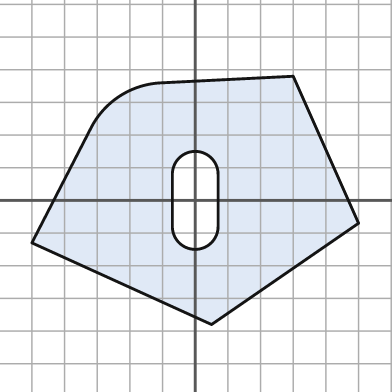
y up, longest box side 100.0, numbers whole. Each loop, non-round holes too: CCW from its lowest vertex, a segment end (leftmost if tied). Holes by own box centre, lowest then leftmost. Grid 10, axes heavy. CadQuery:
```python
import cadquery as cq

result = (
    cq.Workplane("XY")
    .moveTo(5.0, -38.0)
    .lineTo(50.0, -7.0)
    .lineTo(30.0, 38.0)
    .lineTo(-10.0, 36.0)
    .threePointArc((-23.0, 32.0), (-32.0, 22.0))
    .lineTo(-50.0, -13.0)
    .close()
    .moveTo(-7.0, -8.0)
    .threePointArc((0.0, -15.0), (7.0, -8.0))
    .lineTo(7.0, 8.0)
    .threePointArc((0.0, 15.0), (-7.0, 8.0))
    .close()
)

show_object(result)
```